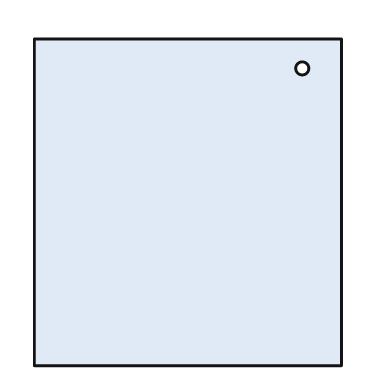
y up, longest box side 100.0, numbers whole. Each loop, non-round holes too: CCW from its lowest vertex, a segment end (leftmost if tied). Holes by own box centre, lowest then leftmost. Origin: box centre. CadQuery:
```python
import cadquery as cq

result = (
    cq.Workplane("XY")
    .moveTo(-47.0, -50.0)
    .lineTo(47.0, -50.0)
    .lineTo(47.0, 50.0)
    .lineTo(-47.0, 50.0)
    .close()
    .moveTo(35.0, 41.0)
    .circle(2.0)
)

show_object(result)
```